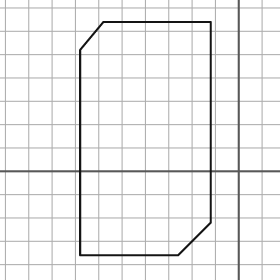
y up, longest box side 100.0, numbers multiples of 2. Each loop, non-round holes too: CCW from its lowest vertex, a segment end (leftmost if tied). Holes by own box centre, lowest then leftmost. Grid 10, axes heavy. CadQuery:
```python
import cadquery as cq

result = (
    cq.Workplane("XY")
    .moveTo(-68.0, -36.0)
    .lineTo(-26.0, -36.0)
    .lineTo(-12.0, -22.0)
    .lineTo(-12.0, 64.0)
    .lineTo(-58.0, 64.0)
    .lineTo(-68.0, 52.0)
    .close()
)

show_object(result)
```